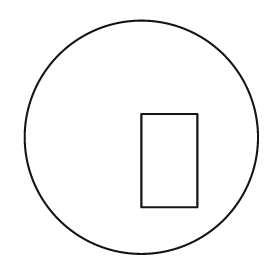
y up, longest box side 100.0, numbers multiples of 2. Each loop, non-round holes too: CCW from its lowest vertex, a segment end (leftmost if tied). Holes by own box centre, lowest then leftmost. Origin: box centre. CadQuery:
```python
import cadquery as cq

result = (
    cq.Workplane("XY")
    .moveTo(0.0, 0.0)
    .circle(50.0)
    .moveTo(0.0, -30.0)
    .lineTo(24.0, -30.0)
    .lineTo(24.0, 10.0)
    .lineTo(0.0, 10.0)
    .close()
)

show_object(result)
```